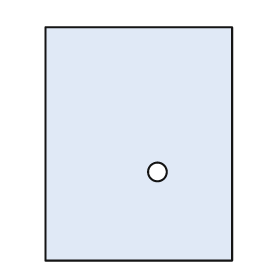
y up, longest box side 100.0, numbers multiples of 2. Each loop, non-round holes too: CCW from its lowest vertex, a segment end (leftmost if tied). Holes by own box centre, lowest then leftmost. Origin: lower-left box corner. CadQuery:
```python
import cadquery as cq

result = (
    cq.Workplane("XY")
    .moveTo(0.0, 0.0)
    .lineTo(80.0, 0.0)
    .lineTo(80.0, 100.0)
    .lineTo(0.0, 100.0)
    .close()
    .moveTo(48.0, 38.0)
    .circle(4.0)
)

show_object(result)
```